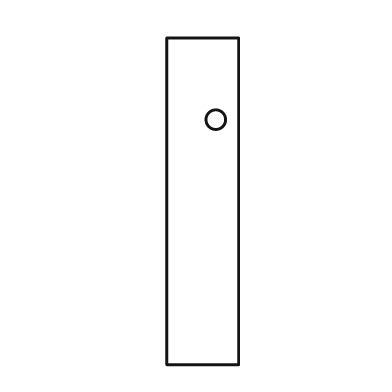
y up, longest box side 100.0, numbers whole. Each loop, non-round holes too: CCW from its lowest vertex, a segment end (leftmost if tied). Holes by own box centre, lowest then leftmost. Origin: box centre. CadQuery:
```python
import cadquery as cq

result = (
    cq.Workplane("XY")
    .moveTo(-11.0, -50.0)
    .lineTo(11.0, -50.0)
    .lineTo(11.0, 50.0)
    .lineTo(-11.0, 50.0)
    .close()
    .moveTo(4.0, 25.0)
    .circle(3.0)
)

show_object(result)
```